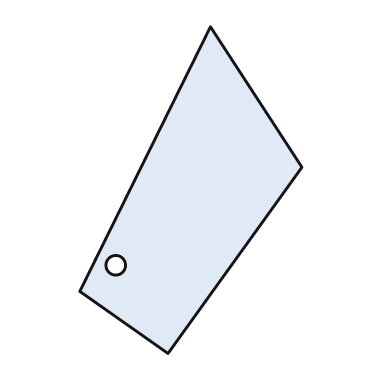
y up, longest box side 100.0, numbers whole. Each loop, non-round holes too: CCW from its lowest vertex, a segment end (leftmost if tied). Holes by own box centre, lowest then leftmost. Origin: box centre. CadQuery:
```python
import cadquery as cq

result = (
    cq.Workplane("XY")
    .moveTo(-7.0, -50.0)
    .lineTo(34.0, 7.0)
    .lineTo(6.0, 50.0)
    .lineTo(-34.0, -31.0)
    .close()
    .moveTo(-23.0, -23.0)
    .circle(3.0)
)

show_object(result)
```